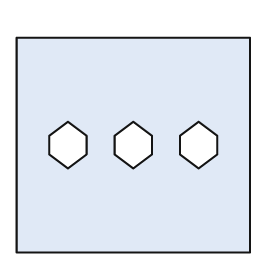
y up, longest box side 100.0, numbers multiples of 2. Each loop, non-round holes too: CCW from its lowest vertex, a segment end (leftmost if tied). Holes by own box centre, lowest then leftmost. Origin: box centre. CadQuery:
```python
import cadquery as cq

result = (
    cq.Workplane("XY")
    .moveTo(-50.0, -46.0)
    .lineTo(50.0, -46.0)
    .lineTo(50.0, 46.0)
    .lineTo(-50.0, 46.0)
    .close()
    .moveTo(-28.0, -10.0)
    .lineTo(-20.0, -4.0)
    .lineTo(-20.0, 4.0)
    .lineTo(-28.0, 10.0)
    .lineTo(-36.0, 4.0)
    .lineTo(-36.0, -4.0)
    .close()
    .moveTo(0.0, -10.0)
    .lineTo(8.0, -4.0)
    .lineTo(8.0, 4.0)
    .lineTo(0.0, 10.0)
    .lineTo(-8.0, 4.0)
    .lineTo(-8.0, -4.0)
    .close()
    .moveTo(28.0, -10.0)
    .lineTo(36.0, -4.0)
    .lineTo(36.0, 4.0)
    .lineTo(28.0, 10.0)
    .lineTo(20.0, 4.0)
    .lineTo(20.0, -4.0)
    .close()
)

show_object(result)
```